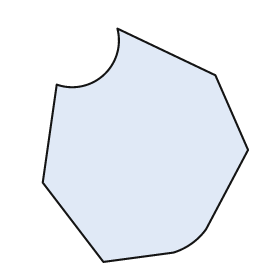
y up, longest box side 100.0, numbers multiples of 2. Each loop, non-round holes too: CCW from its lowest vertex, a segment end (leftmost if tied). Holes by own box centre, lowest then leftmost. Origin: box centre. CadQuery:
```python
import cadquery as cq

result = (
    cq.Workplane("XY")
    .moveTo(-18.0, -50.0)
    .lineTo(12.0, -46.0)
    .threePointArc((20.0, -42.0), (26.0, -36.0))
    .lineTo(44.0, -2.0)
    .lineTo(30.0, 30.0)
    .lineTo(-12.0, 50.0)
    .threePointArc((-18.0, 30.0), (-38.0, 26.0))
    .lineTo(-44.0, -16.0)
    .close()
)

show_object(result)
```